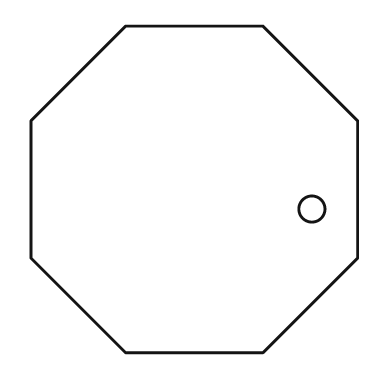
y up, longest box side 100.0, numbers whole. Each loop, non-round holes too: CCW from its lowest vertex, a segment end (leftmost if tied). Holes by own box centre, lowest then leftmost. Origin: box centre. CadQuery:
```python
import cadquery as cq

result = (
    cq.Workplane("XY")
    .moveTo(-21.0, -50.0)
    .lineTo(21.0, -50.0)
    .lineTo(50.0, -21.0)
    .lineTo(50.0, 21.0)
    .lineTo(21.0, 50.0)
    .lineTo(-21.0, 50.0)
    .lineTo(-50.0, 21.0)
    .lineTo(-50.0, -21.0)
    .close()
    .moveTo(36.0, -6.0)
    .circle(4.0)
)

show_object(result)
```